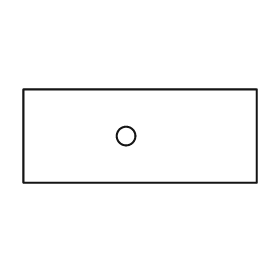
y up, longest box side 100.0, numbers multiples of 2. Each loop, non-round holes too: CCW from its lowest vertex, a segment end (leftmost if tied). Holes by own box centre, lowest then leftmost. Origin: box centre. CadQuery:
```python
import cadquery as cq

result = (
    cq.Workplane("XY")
    .moveTo(-50.0, -20.0)
    .lineTo(50.0, -20.0)
    .lineTo(50.0, 20.0)
    .lineTo(-50.0, 20.0)
    .close()
    .moveTo(-6.0, 0.0)
    .circle(4.0)
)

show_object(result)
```